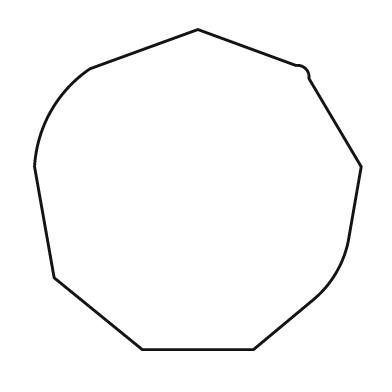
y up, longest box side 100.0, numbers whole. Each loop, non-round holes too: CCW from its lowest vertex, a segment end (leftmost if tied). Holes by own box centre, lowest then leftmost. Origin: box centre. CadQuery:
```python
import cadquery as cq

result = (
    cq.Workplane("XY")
    .moveTo(-17.0, -49.0)
    .lineTo(17.0, -49.0)
    .lineTo(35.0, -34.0)
    .threePointArc((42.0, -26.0), (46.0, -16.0))
    .lineTo(50.0, 7.0)
    .lineTo(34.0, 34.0)
    .threePointArc((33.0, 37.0), (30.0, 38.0))
    .lineTo(0.0, 49.0)
    .lineTo(-33.0, 37.0)
    .threePointArc((-45.0, 24.0), (-50.0, 7.0))
    .lineTo(-44.0, -27.0)
    .close()
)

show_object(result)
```